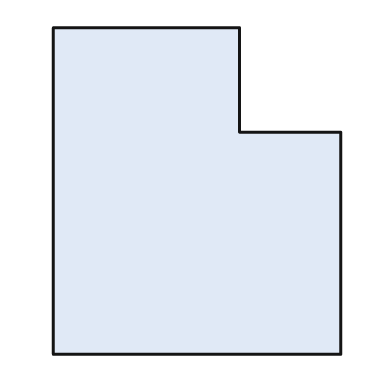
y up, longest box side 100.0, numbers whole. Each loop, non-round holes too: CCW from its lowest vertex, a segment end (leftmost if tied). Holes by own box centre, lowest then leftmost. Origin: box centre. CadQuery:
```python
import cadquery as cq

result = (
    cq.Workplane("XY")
    .moveTo(-44.0, -50.0)
    .lineTo(44.0, -50.0)
    .lineTo(44.0, 18.0)
    .lineTo(13.0, 18.0)
    .lineTo(13.0, 50.0)
    .lineTo(-44.0, 50.0)
    .close()
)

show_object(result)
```